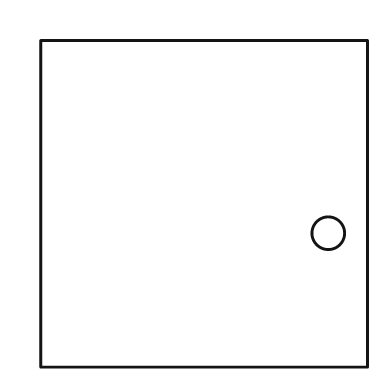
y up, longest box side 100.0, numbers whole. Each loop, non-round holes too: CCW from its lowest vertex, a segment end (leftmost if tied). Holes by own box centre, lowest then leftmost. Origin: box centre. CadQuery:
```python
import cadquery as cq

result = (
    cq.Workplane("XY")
    .moveTo(-50.0, -50.0)
    .lineTo(50.0, -50.0)
    .lineTo(50.0, 50.0)
    .lineTo(-50.0, 50.0)
    .close()
    .moveTo(38.0, -9.0)
    .circle(5.0)
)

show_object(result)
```